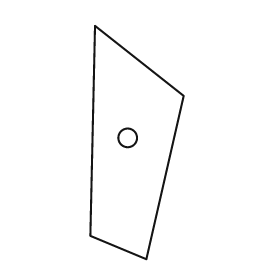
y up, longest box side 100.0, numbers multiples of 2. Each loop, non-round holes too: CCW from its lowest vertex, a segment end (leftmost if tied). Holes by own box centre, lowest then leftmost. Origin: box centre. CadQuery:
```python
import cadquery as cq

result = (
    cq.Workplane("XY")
    .moveTo(4.0, -50.0)
    .lineTo(20.0, 20.0)
    .lineTo(-18.0, 50.0)
    .lineTo(-20.0, -40.0)
    .close()
    .moveTo(-4.0, 2.0)
    .circle(4.0)
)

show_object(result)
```